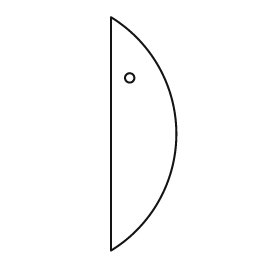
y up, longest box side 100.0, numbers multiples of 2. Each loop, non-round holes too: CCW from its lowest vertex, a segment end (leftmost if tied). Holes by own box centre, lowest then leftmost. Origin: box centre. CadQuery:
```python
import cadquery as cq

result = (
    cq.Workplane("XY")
    .moveTo(-14.0, -50.0)
    .threePointArc((14.0, 0.0), (-14.0, 50.0))
    .close()
    .moveTo(-6.0, 24.0)
    .circle(2.0)
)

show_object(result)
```